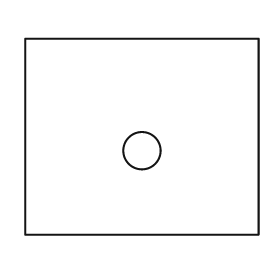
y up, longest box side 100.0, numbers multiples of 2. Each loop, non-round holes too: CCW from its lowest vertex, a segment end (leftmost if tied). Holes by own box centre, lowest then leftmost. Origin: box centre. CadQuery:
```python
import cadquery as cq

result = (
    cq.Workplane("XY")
    .moveTo(-50.0, -42.0)
    .lineTo(50.0, -42.0)
    .lineTo(50.0, 42.0)
    .lineTo(-50.0, 42.0)
    .close()
    .moveTo(0.0, -6.0)
    .circle(8.0)
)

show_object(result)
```